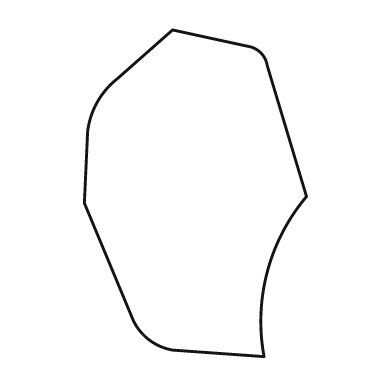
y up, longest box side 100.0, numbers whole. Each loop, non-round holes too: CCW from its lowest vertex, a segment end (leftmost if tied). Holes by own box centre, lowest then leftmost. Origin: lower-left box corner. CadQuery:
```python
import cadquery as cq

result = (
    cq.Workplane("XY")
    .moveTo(55.0, 0.0)
    .threePointArc((56.0, 26.0), (68.0, 49.0))
    .lineTo(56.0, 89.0)
    .threePointArc((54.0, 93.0), (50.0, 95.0))
    .lineTo(27.0, 100.0)
    .lineTo(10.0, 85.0)
    .threePointArc((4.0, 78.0), (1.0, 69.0))
    .lineTo(0.0, 47.0)
    .lineTo(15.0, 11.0)
    .threePointArc((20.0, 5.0), (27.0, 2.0))
    .close()
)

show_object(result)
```